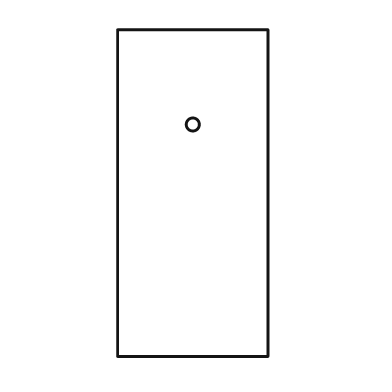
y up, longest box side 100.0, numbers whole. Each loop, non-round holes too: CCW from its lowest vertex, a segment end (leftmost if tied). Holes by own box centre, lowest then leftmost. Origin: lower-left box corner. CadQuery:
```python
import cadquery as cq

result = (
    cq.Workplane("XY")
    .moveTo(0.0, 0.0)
    .lineTo(46.0, 0.0)
    .lineTo(46.0, 100.0)
    .lineTo(0.0, 100.0)
    .close()
    .moveTo(23.0, 71.0)
    .circle(2.0)
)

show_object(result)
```